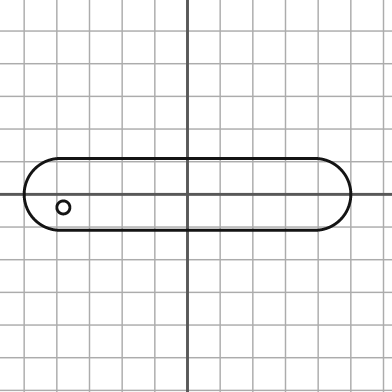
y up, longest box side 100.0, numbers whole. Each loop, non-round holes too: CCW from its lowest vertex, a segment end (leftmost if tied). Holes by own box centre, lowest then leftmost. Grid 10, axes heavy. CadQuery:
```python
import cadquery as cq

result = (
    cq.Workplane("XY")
    .moveTo(-39.0, -11.0)
    .lineTo(39.0, -11.0)
    .threePointArc((50.0, 0.0), (39.0, 11.0))
    .lineTo(-39.0, 11.0)
    .threePointArc((-50.0, 0.0), (-39.0, -11.0))
    .close()
    .moveTo(-38.0, -4.0)
    .circle(2.0)
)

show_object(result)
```